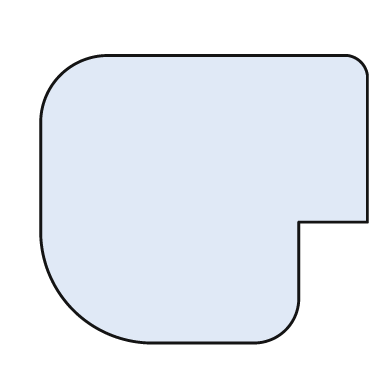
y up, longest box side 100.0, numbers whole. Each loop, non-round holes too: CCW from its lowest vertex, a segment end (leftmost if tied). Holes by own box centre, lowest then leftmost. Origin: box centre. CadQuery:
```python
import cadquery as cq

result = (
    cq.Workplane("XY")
    .moveTo(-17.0, -44.0)
    .lineTo(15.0, -44.0)
    .threePointArc((25.0, -40.0), (29.0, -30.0))
    .lineTo(29.0, -7.0)
    .lineTo(50.0, -7.0)
    .lineTo(50.0, 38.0)
    .threePointArc((48.0, 42.0), (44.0, 44.0))
    .lineTo(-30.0, 44.0)
    .threePointArc((-44.0, 38.0), (-50.0, 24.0))
    .lineTo(-50.0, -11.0)
    .threePointArc((-40.0, -34.0), (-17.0, -44.0))
    .close()
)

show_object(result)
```